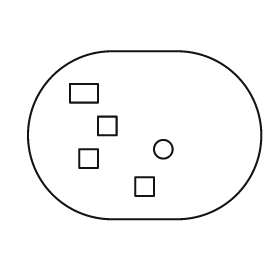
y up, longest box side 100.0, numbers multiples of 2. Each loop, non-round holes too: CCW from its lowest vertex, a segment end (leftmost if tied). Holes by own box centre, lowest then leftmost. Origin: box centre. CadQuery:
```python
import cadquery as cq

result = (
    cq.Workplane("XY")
    .moveTo(-14.0, -36.0)
    .lineTo(14.0, -36.0)
    .threePointArc((50.0, 0.0), (14.0, 36.0))
    .lineTo(-14.0, 36.0)
    .threePointArc((-50.0, 0.0), (-14.0, -36.0))
    .close()
    .moveTo(-4.0, -26.0)
    .lineTo(4.0, -26.0)
    .lineTo(4.0, -18.0)
    .lineTo(-4.0, -18.0)
    .close()
    .moveTo(-28.0, -14.0)
    .lineTo(-20.0, -14.0)
    .lineTo(-20.0, -6.0)
    .lineTo(-28.0, -6.0)
    .close()
    .moveTo(8.0, -6.0)
    .circle(4.0)
    .moveTo(-20.0, 0.0)
    .lineTo(-12.0, 0.0)
    .lineTo(-12.0, 8.0)
    .lineTo(-20.0, 8.0)
    .close()
    .moveTo(-32.0, 14.0)
    .lineTo(-20.0, 14.0)
    .lineTo(-20.0, 22.0)
    .lineTo(-32.0, 22.0)
    .close()
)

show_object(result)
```